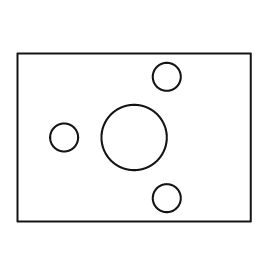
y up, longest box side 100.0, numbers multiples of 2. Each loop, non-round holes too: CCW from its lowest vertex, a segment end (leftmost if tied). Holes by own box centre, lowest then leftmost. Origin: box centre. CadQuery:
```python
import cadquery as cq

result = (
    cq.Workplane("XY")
    .moveTo(-50.0, -36.0)
    .lineTo(50.0, -36.0)
    .lineTo(50.0, 36.0)
    .lineTo(-50.0, 36.0)
    .close()
    .moveTo(14.0, -26.0)
    .circle(6.0)
    .moveTo(-30.0, 0.0)
    .circle(6.0)
    .moveTo(0.0, 0.0)
    .circle(14.0)
    .moveTo(14.0, 26.0)
    .circle(6.0)
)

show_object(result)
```